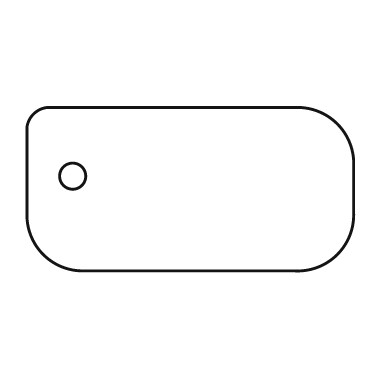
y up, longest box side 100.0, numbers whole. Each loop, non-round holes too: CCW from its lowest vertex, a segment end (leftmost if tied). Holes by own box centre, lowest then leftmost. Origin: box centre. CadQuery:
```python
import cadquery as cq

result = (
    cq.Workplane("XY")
    .moveTo(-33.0, -25.0)
    .lineTo(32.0, -25.0)
    .threePointArc((45.0, -20.0), (50.0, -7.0))
    .lineTo(50.0, 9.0)
    .threePointArc((45.0, 20.0), (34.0, 25.0))
    .lineTo(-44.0, 25.0)
    .threePointArc((-48.0, 23.0), (-50.0, 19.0))
    .lineTo(-50.0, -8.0)
    .threePointArc((-45.0, -20.0), (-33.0, -25.0))
    .close()
    .moveTo(-36.0, 4.0)
    .circle(4.0)
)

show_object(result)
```